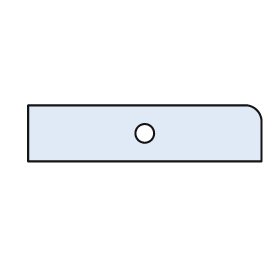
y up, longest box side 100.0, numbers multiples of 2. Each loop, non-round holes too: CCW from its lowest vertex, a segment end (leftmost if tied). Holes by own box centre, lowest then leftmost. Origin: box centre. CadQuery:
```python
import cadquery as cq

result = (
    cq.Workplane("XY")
    .moveTo(-50.0, -12.0)
    .lineTo(50.0, -12.0)
    .lineTo(50.0, 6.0)
    .threePointArc((48.0, 10.0), (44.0, 12.0))
    .lineTo(-50.0, 12.0)
    .close()
    .moveTo(0.0, 0.0)
    .circle(4.0)
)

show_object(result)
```